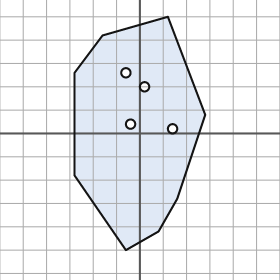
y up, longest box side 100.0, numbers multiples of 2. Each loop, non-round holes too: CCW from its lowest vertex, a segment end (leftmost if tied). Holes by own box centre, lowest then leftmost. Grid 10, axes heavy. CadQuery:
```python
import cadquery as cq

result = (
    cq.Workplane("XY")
    .moveTo(-6.0, -50.0)
    .lineTo(8.0, -42.0)
    .lineTo(16.0, -28.0)
    .lineTo(28.0, 8.0)
    .lineTo(12.0, 50.0)
    .lineTo(-16.0, 42.0)
    .lineTo(-28.0, 26.0)
    .lineTo(-28.0, -18.0)
    .close()
    .moveTo(14.0, 2.0)
    .circle(2.0)
    .moveTo(-4.0, 4.0)
    .circle(2.0)
    .moveTo(2.0, 20.0)
    .circle(2.0)
    .moveTo(-6.0, 26.0)
    .circle(2.0)
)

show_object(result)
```